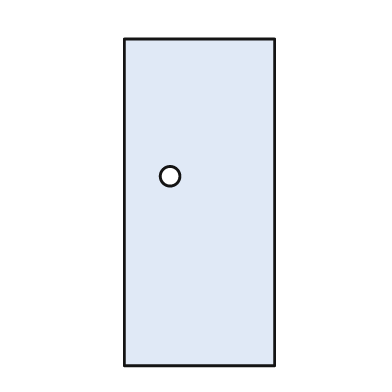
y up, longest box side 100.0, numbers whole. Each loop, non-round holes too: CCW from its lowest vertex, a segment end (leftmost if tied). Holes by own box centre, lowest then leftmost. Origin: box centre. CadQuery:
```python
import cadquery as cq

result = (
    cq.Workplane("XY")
    .moveTo(-23.0, -50.0)
    .lineTo(23.0, -50.0)
    .lineTo(23.0, 50.0)
    .lineTo(-23.0, 50.0)
    .close()
    .moveTo(-9.0, 8.0)
    .circle(3.0)
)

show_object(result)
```